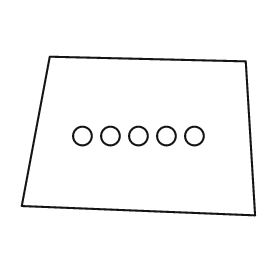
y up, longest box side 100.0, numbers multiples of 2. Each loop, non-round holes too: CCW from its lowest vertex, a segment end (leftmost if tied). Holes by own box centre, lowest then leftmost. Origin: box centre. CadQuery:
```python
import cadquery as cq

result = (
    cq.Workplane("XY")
    .moveTo(50.0, -34.0)
    .lineTo(46.0, 32.0)
    .lineTo(-38.0, 34.0)
    .lineTo(-50.0, -30.0)
    .close()
    .moveTo(-24.0, 0.0)
    .circle(4.0)
    .moveTo(-12.0, 0.0)
    .circle(4.0)
    .moveTo(0.0, 0.0)
    .circle(4.0)
    .moveTo(12.0, 0.0)
    .circle(4.0)
    .moveTo(24.0, 0.0)
    .circle(4.0)
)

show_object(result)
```